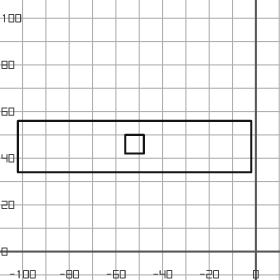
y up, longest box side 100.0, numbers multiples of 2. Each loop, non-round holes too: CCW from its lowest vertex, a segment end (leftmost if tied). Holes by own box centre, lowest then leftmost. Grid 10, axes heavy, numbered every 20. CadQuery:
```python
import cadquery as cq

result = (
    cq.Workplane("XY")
    .moveTo(-102.0, 34.0)
    .lineTo(-2.0, 34.0)
    .lineTo(-2.0, 56.0)
    .lineTo(-102.0, 56.0)
    .close()
    .moveTo(-56.0, 42.0)
    .lineTo(-48.0, 42.0)
    .lineTo(-48.0, 50.0)
    .lineTo(-56.0, 50.0)
    .close()
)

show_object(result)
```